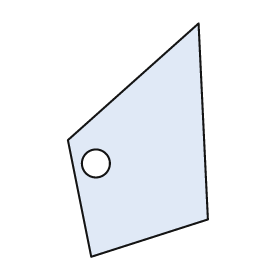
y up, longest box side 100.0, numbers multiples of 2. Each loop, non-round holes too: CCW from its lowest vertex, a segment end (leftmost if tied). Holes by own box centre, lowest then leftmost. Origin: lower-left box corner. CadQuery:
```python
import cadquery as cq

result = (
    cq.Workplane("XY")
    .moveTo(10.0, 0.0)
    .lineTo(60.0, 16.0)
    .lineTo(56.0, 100.0)
    .lineTo(0.0, 50.0)
    .close()
    .moveTo(12.0, 40.0)
    .circle(6.0)
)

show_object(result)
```